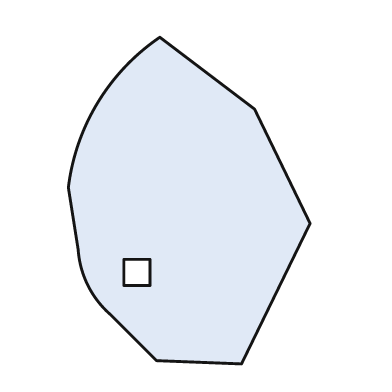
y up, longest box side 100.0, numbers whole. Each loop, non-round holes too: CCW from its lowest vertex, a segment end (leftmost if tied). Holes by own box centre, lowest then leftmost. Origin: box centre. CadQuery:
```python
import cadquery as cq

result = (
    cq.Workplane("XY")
    .moveTo(16.0, -50.0)
    .lineTo(37.0, -7.0)
    .lineTo(20.0, 28.0)
    .lineTo(-9.0, 50.0)
    .threePointArc((-28.0, 30.0), (-37.0, 4.0))
    .lineTo(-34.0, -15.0)
    .threePointArc((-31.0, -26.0), (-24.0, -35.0))
    .lineTo(-10.0, -49.0)
    .close()
    .moveTo(-20.0, -26.0)
    .lineTo(-12.0, -26.0)
    .lineTo(-12.0, -18.0)
    .lineTo(-20.0, -18.0)
    .close()
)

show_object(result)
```